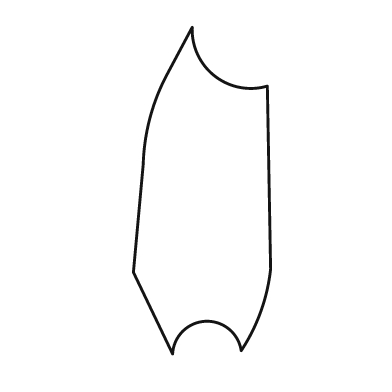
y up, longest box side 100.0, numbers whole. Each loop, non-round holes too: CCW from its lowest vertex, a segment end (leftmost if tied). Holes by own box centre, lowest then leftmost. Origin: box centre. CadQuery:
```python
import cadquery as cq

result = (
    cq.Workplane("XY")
    .moveTo(-9.0, -50.0)
    .threePointArc((1.0, -40.0), (12.0, -49.0))
    .threePointArc((18.0, -37.0), (21.0, -24.0))
    .lineTo(20.0, 32.0)
    .threePointArc((4.0, 35.0), (-3.0, 50.0))
    .lineTo(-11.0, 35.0)
    .threePointArc((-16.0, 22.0), (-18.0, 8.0))
    .lineTo(-21.0, -25.0)
    .close()
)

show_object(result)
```